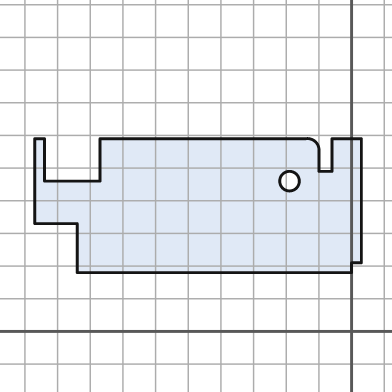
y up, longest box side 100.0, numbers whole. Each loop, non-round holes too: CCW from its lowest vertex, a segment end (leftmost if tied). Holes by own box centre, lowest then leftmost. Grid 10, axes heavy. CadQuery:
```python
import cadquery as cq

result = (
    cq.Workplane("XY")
    .moveTo(-84.0, 18.0)
    .lineTo(0.0, 18.0)
    .lineTo(0.0, 21.0)
    .lineTo(3.0, 21.0)
    .lineTo(3.0, 59.0)
    .lineTo(-6.0, 59.0)
    .lineTo(-6.0, 49.0)
    .lineTo(-10.0, 49.0)
    .lineTo(-10.0, 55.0)
    .threePointArc((-11.0, 58.0), (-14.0, 59.0))
    .lineTo(-77.0, 59.0)
    .lineTo(-77.0, 46.0)
    .lineTo(-94.0, 46.0)
    .lineTo(-94.0, 59.0)
    .lineTo(-97.0, 59.0)
    .lineTo(-97.0, 33.0)
    .lineTo(-84.0, 33.0)
    .close()
    .moveTo(-19.0, 46.0)
    .circle(3.0)
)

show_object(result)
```